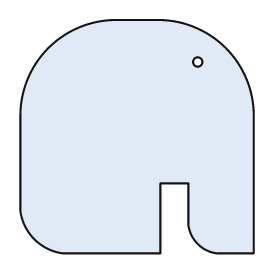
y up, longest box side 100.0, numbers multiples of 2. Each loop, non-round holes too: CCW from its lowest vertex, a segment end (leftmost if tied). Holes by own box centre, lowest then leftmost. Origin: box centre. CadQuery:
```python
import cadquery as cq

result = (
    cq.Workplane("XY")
    .moveTo(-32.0, -50.0)
    .lineTo(10.0, -50.0)
    .lineTo(10.0, -20.0)
    .lineTo(22.0, -20.0)
    .lineTo(22.0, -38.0)
    .threePointArc((26.0, -46.0), (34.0, -50.0))
    .lineTo(50.0, -50.0)
    .lineTo(50.0, 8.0)
    .threePointArc((38.0, 38.0), (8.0, 50.0))
    .lineTo(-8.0, 50.0)
    .threePointArc((-38.0, 38.0), (-50.0, 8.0))
    .lineTo(-50.0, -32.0)
    .threePointArc((-44.0, -44.0), (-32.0, -50.0))
    .close()
    .moveTo(26.0, 32.0)
    .circle(2.0)
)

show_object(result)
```